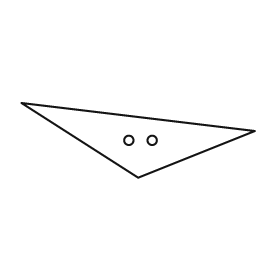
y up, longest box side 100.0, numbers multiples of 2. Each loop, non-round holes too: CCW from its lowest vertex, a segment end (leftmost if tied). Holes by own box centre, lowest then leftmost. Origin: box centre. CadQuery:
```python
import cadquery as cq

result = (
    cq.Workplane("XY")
    .moveTo(0.0, -16.0)
    .lineTo(50.0, 4.0)
    .lineTo(-50.0, 16.0)
    .close()
    .moveTo(-4.0, 0.0)
    .circle(2.0)
    .moveTo(6.0, 0.0)
    .circle(2.0)
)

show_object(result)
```